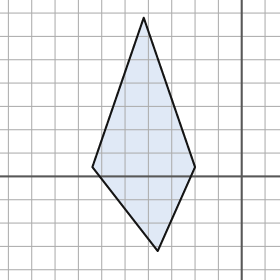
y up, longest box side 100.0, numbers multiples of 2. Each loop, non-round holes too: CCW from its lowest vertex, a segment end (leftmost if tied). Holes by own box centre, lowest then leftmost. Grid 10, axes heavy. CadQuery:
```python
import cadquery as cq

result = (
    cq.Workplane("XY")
    .moveTo(-36.0, -32.0)
    .lineTo(-20.0, 4.0)
    .lineTo(-42.0, 68.0)
    .lineTo(-64.0, 4.0)
    .close()
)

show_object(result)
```